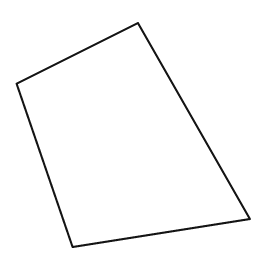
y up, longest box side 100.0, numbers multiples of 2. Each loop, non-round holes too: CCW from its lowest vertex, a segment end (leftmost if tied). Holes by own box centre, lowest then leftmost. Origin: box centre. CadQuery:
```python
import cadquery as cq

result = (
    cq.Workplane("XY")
    .moveTo(-26.0, -48.0)
    .lineTo(50.0, -36.0)
    .lineTo(2.0, 48.0)
    .lineTo(-50.0, 22.0)
    .close()
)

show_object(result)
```